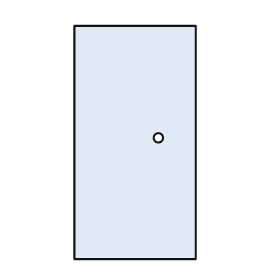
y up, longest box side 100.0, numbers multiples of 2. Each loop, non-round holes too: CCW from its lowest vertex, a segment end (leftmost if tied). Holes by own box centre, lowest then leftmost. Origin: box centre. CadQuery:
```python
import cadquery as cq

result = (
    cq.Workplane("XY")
    .moveTo(-26.0, -50.0)
    .lineTo(26.0, -50.0)
    .lineTo(26.0, 50.0)
    .lineTo(-26.0, 50.0)
    .close()
    .moveTo(10.0, 2.0)
    .circle(2.0)
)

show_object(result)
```